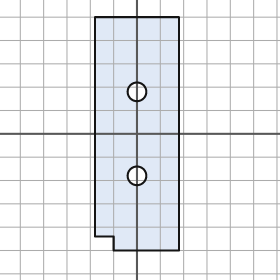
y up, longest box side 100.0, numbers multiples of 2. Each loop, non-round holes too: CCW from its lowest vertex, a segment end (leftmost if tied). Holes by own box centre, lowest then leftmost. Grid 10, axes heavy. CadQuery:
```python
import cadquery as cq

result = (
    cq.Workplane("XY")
    .moveTo(-10.0, -50.0)
    .lineTo(18.0, -50.0)
    .lineTo(18.0, 50.0)
    .lineTo(-18.0, 50.0)
    .lineTo(-18.0, -44.0)
    .lineTo(-10.0, -44.0)
    .close()
    .moveTo(0.0, -18.0)
    .circle(4.0)
    .moveTo(0.0, 18.0)
    .circle(4.0)
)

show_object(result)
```